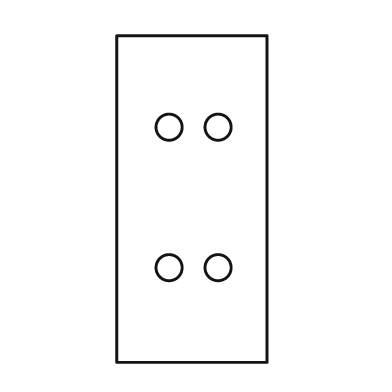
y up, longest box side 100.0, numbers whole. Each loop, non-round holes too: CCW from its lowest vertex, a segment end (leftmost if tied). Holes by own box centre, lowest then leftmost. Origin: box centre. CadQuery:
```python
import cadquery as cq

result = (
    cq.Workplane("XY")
    .moveTo(-23.0, -50.0)
    .lineTo(23.0, -50.0)
    .lineTo(23.0, 50.0)
    .lineTo(-23.0, 50.0)
    .close()
    .moveTo(-7.0, -21.0)
    .circle(4.0)
    .moveTo(8.0, -21.0)
    .circle(4.0)
    .moveTo(-7.0, 22.0)
    .circle(4.0)
    .moveTo(8.0, 22.0)
    .circle(4.0)
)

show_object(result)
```